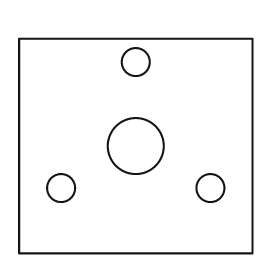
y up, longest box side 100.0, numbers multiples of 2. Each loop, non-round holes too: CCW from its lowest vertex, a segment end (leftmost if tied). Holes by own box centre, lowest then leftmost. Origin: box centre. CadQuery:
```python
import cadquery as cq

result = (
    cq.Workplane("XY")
    .moveTo(-50.0, -46.0)
    .lineTo(50.0, -46.0)
    .lineTo(50.0, 46.0)
    .lineTo(-50.0, 46.0)
    .close()
    .moveTo(-32.0, -18.0)
    .circle(6.0)
    .moveTo(32.0, -18.0)
    .circle(6.0)
    .moveTo(0.0, 0.0)
    .circle(12.0)
    .moveTo(0.0, 36.0)
    .circle(6.0)
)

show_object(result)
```